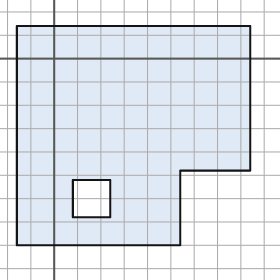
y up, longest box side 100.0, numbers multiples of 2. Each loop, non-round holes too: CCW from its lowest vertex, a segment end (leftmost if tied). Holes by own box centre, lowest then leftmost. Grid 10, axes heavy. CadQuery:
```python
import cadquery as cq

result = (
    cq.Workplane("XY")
    .moveTo(-16.0, -80.0)
    .lineTo(54.0, -80.0)
    .lineTo(54.0, -48.0)
    .lineTo(84.0, -48.0)
    .lineTo(84.0, 14.0)
    .lineTo(-16.0, 14.0)
    .close()
    .moveTo(8.0, -68.0)
    .lineTo(24.0, -68.0)
    .lineTo(24.0, -52.0)
    .lineTo(8.0, -52.0)
    .close()
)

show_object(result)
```